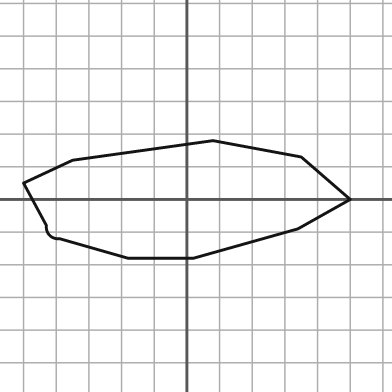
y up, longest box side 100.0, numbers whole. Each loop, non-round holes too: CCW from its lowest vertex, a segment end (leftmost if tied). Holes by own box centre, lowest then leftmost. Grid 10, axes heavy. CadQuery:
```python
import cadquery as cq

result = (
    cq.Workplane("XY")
    .moveTo(-18.0, -18.0)
    .lineTo(2.0, -18.0)
    .lineTo(34.0, -9.0)
    .lineTo(50.0, 0.0)
    .lineTo(35.0, 13.0)
    .lineTo(8.0, 18.0)
    .lineTo(-35.0, 12.0)
    .lineTo(-50.0, 5.0)
    .lineTo(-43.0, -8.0)
    .threePointArc((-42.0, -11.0), (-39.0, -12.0))
    .close()
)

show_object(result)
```